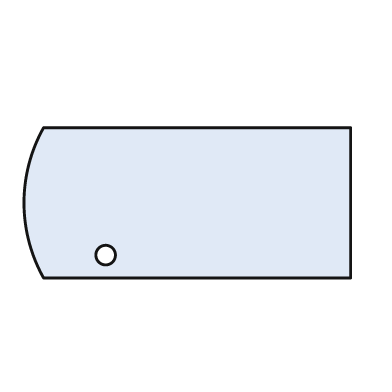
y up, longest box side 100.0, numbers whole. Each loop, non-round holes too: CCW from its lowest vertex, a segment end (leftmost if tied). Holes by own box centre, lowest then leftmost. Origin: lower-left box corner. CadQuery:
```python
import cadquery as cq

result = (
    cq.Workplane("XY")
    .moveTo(6.0, 0.0)
    .lineTo(100.0, 0.0)
    .lineTo(100.0, 46.0)
    .lineTo(6.0, 46.0)
    .threePointArc((0.0, 23.0), (6.0, 0.0))
    .close()
    .moveTo(25.0, 7.0)
    .circle(3.0)
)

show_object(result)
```